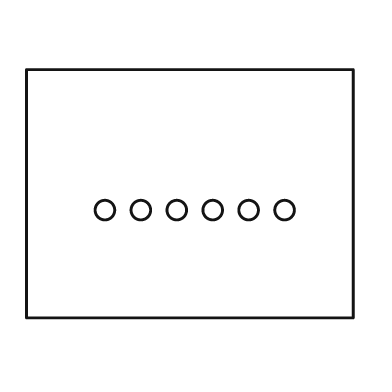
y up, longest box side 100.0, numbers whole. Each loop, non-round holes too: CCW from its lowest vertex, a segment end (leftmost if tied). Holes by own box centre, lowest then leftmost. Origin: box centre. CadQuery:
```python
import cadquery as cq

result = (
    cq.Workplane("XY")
    .moveTo(-50.0, -38.0)
    .lineTo(50.0, -38.0)
    .lineTo(50.0, 38.0)
    .lineTo(-50.0, 38.0)
    .close()
    .moveTo(-26.0, -5.0)
    .circle(3.0)
    .moveTo(-15.0, -5.0)
    .circle(3.0)
    .moveTo(-4.0, -5.0)
    .circle(3.0)
    .moveTo(7.0, -5.0)
    .circle(3.0)
    .moveTo(18.0, -5.0)
    .circle(3.0)
    .moveTo(29.0, -5.0)
    .circle(3.0)
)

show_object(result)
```